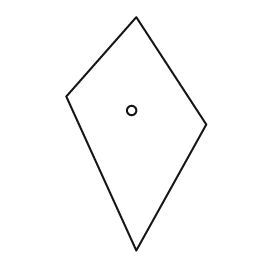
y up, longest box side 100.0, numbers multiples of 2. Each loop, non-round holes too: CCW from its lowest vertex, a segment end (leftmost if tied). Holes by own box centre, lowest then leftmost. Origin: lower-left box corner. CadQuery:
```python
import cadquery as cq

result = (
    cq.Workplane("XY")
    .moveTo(30.0, 0.0)
    .lineTo(60.0, 54.0)
    .lineTo(30.0, 100.0)
    .lineTo(0.0, 66.0)
    .close()
    .moveTo(28.0, 60.0)
    .circle(2.0)
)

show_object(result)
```